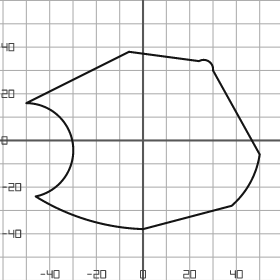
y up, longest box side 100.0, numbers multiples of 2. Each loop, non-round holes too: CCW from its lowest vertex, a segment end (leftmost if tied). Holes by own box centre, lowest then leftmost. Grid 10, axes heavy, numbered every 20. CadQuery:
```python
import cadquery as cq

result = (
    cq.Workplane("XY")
    .moveTo(0.0, -38.0)
    .lineTo(38.0, -28.0)
    .threePointArc((46.0, -18.0), (50.0, -6.0))
    .lineTo(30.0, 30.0)
    .threePointArc((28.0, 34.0), (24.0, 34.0))
    .lineTo(-6.0, 38.0)
    .lineTo(-50.0, 16.0)
    .threePointArc((-30.0, -2.0), (-46.0, -24.0))
    .threePointArc((-24.0, -34.0), (0.0, -38.0))
    .close()
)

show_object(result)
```